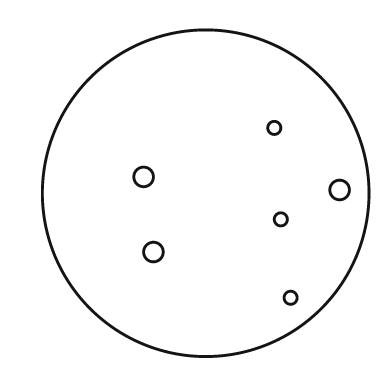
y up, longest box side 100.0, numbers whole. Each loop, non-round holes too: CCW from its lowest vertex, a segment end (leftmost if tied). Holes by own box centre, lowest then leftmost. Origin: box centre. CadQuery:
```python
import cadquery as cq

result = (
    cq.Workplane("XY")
    .moveTo(0.0, 0.0)
    .circle(50.0)
    .moveTo(26.0, -32.0)
    .circle(2.0)
    .moveTo(-16.0, -18.0)
    .circle(3.0)
    .moveTo(23.0, -8.0)
    .circle(2.0)
    .moveTo(41.0, 1.0)
    .circle(3.0)
    .moveTo(-19.0, 5.0)
    .circle(3.0)
    .moveTo(21.0, 20.0)
    .circle(2.0)
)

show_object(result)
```